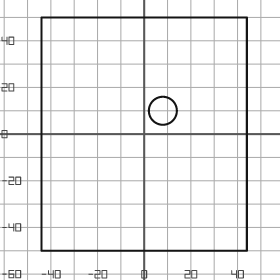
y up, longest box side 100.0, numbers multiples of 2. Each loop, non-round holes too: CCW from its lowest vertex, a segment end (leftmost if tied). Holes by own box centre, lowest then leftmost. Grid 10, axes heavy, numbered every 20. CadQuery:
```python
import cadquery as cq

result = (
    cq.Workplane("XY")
    .moveTo(-44.0, -50.0)
    .lineTo(44.0, -50.0)
    .lineTo(44.0, 50.0)
    .lineTo(-44.0, 50.0)
    .close()
    .moveTo(8.0, 10.0)
    .circle(6.0)
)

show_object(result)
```